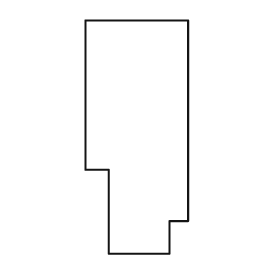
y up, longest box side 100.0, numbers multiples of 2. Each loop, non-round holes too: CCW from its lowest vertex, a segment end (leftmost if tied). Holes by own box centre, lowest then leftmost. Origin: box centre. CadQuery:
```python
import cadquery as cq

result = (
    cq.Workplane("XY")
    .moveTo(-12.0, -50.0)
    .lineTo(14.0, -50.0)
    .lineTo(14.0, -36.0)
    .lineTo(22.0, -36.0)
    .lineTo(22.0, 50.0)
    .lineTo(-22.0, 50.0)
    .lineTo(-22.0, -14.0)
    .lineTo(-12.0, -14.0)
    .close()
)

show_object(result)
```